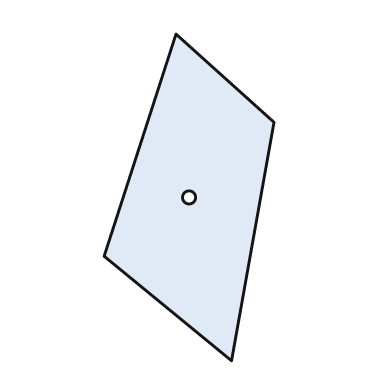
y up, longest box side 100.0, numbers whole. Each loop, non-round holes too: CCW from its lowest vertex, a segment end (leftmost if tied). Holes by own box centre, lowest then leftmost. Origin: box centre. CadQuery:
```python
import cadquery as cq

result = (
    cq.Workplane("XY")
    .moveTo(13.0, -50.0)
    .lineTo(26.0, 23.0)
    .lineTo(-4.0, 50.0)
    .lineTo(-26.0, -18.0)
    .close()
    .moveTo(0.0, 0.0)
    .circle(2.0)
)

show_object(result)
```